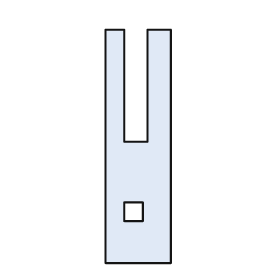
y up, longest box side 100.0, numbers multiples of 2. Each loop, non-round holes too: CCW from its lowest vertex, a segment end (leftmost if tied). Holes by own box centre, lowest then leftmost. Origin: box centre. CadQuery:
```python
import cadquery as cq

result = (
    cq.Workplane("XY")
    .moveTo(-14.0, -50.0)
    .lineTo(14.0, -50.0)
    .lineTo(14.0, 50.0)
    .lineTo(4.0, 50.0)
    .lineTo(4.0, 2.0)
    .lineTo(-6.0, 2.0)
    .lineTo(-6.0, 50.0)
    .lineTo(-14.0, 50.0)
    .close()
    .moveTo(-6.0, -32.0)
    .lineTo(2.0, -32.0)
    .lineTo(2.0, -24.0)
    .lineTo(-6.0, -24.0)
    .close()
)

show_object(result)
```